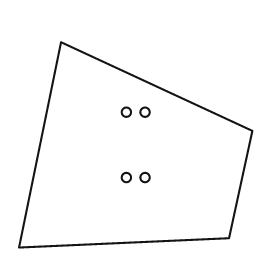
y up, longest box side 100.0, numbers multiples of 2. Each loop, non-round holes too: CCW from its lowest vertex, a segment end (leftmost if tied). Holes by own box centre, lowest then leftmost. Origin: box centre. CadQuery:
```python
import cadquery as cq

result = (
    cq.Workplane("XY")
    .moveTo(-50.0, -44.0)
    .lineTo(40.0, -40.0)
    .lineTo(50.0, 6.0)
    .lineTo(-32.0, 44.0)
    .close()
    .moveTo(-4.0, -14.0)
    .circle(2.0)
    .moveTo(4.0, -14.0)
    .circle(2.0)
    .moveTo(-4.0, 14.0)
    .circle(2.0)
    .moveTo(4.0, 14.0)
    .circle(2.0)
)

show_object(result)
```